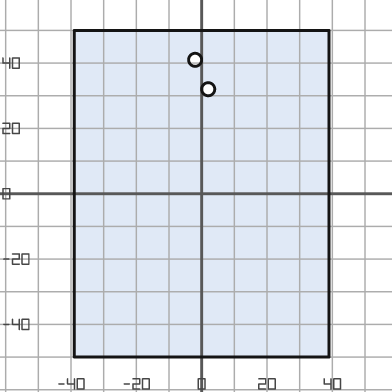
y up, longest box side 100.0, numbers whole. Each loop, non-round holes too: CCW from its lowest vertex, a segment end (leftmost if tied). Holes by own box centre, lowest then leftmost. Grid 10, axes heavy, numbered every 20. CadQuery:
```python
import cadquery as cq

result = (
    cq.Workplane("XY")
    .moveTo(-39.0, -50.0)
    .lineTo(39.0, -50.0)
    .lineTo(39.0, 50.0)
    .lineTo(-39.0, 50.0)
    .close()
    .moveTo(2.0, 32.0)
    .circle(2.0)
    .moveTo(-2.0, 41.0)
    .circle(2.0)
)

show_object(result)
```